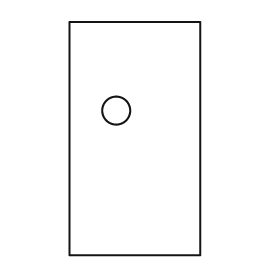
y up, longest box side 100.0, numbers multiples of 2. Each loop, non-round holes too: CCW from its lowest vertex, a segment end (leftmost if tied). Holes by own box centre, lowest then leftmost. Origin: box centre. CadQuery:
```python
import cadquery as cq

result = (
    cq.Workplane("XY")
    .moveTo(-28.0, -50.0)
    .lineTo(28.0, -50.0)
    .lineTo(28.0, 50.0)
    .lineTo(-28.0, 50.0)
    .close()
    .moveTo(-8.0, 12.0)
    .circle(6.0)
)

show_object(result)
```